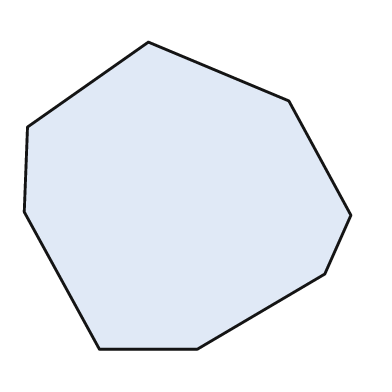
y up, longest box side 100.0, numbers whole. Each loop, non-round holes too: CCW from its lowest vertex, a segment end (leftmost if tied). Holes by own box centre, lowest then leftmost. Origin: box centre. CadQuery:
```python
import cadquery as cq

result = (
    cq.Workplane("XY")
    .moveTo(-27.0, -47.0)
    .lineTo(3.0, -47.0)
    .lineTo(42.0, -24.0)
    .lineTo(50.0, -6.0)
    .lineTo(31.0, 29.0)
    .lineTo(-12.0, 47.0)
    .lineTo(-49.0, 21.0)
    .lineTo(-50.0, -5.0)
    .close()
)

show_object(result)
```